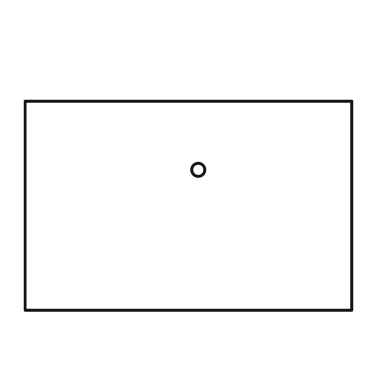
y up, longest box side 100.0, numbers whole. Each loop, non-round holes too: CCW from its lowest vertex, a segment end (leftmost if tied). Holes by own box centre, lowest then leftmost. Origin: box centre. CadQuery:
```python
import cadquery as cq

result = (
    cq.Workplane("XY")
    .moveTo(-50.0, -32.0)
    .lineTo(50.0, -32.0)
    .lineTo(50.0, 32.0)
    .lineTo(-50.0, 32.0)
    .close()
    .moveTo(3.0, 11.0)
    .circle(2.0)
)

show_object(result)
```